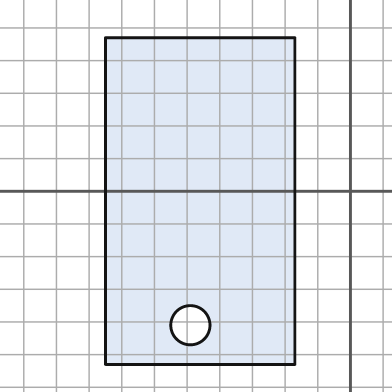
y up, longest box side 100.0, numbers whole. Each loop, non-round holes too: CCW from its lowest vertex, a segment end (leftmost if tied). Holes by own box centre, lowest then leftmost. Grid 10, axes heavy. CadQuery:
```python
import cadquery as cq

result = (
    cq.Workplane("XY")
    .moveTo(-75.0, -53.0)
    .lineTo(-17.0, -53.0)
    .lineTo(-17.0, 47.0)
    .lineTo(-75.0, 47.0)
    .close()
    .moveTo(-49.0, -41.0)
    .circle(6.0)
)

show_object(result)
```